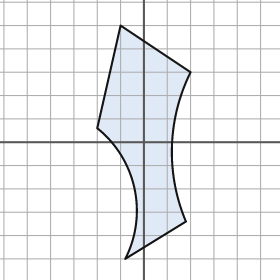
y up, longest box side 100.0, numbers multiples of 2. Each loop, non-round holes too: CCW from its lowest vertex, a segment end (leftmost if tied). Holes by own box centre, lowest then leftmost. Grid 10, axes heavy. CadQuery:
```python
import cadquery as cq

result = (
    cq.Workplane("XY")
    .moveTo(-8.0, -50.0)
    .lineTo(18.0, -34.0)
    .threePointArc((12.0, -2.0), (20.0, 30.0))
    .lineTo(-10.0, 50.0)
    .lineTo(-20.0, 6.0)
    .threePointArc((-4.0, -20.0), (-8.0, -50.0))
    .close()
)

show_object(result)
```